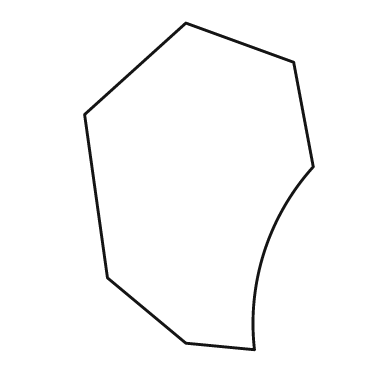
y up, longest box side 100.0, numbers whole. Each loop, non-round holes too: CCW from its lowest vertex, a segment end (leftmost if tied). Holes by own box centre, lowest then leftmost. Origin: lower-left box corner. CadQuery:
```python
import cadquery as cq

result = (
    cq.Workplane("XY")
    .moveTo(52.0, 0.0)
    .threePointArc((55.0, 30.0), (70.0, 56.0))
    .lineTo(64.0, 88.0)
    .lineTo(31.0, 100.0)
    .lineTo(0.0, 72.0)
    .lineTo(7.0, 22.0)
    .lineTo(31.0, 2.0)
    .close()
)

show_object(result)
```